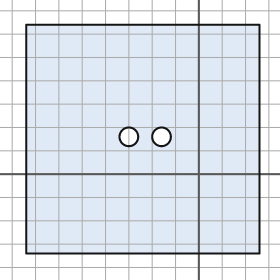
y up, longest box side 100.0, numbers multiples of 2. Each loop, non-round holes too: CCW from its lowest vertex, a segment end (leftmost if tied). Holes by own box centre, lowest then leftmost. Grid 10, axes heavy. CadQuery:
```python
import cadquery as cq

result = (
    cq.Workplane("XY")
    .moveTo(-74.0, -34.0)
    .lineTo(26.0, -34.0)
    .lineTo(26.0, 64.0)
    .lineTo(-74.0, 64.0)
    .close()
    .moveTo(-30.0, 16.0)
    .circle(4.0)
    .moveTo(-16.0, 16.0)
    .circle(4.0)
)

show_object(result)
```